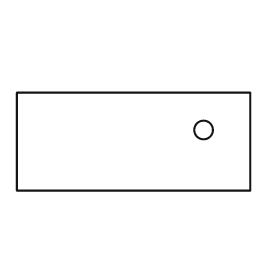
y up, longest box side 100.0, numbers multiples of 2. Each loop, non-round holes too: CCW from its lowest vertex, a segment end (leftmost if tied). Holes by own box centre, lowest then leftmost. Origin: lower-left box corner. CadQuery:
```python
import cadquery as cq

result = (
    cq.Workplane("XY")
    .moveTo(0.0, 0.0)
    .lineTo(100.0, 0.0)
    .lineTo(100.0, 42.0)
    .lineTo(0.0, 42.0)
    .close()
    .moveTo(80.0, 26.0)
    .circle(4.0)
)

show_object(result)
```